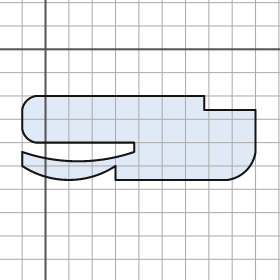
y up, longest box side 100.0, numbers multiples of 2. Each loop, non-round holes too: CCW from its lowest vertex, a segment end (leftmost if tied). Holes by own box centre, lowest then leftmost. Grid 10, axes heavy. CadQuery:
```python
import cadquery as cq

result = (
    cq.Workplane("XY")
    .moveTo(30.0, -56.0)
    .lineTo(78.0, -56.0)
    .threePointArc((86.0, -52.0), (90.0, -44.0))
    .lineTo(90.0, -26.0)
    .lineTo(68.0, -26.0)
    .lineTo(68.0, -20.0)
    .lineTo(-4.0, -20.0)
    .threePointArc((-8.0, -22.0), (-10.0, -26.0))
    .lineTo(-10.0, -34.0)
    .threePointArc((-8.0, -38.0), (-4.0, -40.0))
    .lineTo(38.0, -40.0)
    .lineTo(38.0, -44.0)
    .threePointArc((14.0, -48.0), (-10.0, -44.0))
    .lineTo(-10.0, -50.0)
    .threePointArc((10.0, -56.0), (30.0, -50.0))
    .close()
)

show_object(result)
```